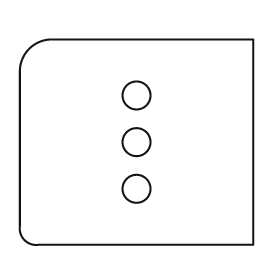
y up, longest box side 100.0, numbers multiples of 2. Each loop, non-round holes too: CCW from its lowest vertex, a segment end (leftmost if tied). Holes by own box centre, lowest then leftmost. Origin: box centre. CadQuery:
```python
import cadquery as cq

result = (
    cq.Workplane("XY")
    .moveTo(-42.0, -44.0)
    .lineTo(50.0, -44.0)
    .lineTo(50.0, 44.0)
    .lineTo(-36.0, 44.0)
    .threePointArc((-46.0, 40.0), (-50.0, 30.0))
    .lineTo(-50.0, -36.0)
    .threePointArc((-48.0, -42.0), (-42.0, -44.0))
    .close()
    .moveTo(0.0, -20.0)
    .circle(6.0)
    .moveTo(0.0, 0.0)
    .circle(6.0)
    .moveTo(0.0, 20.0)
    .circle(6.0)
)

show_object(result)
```